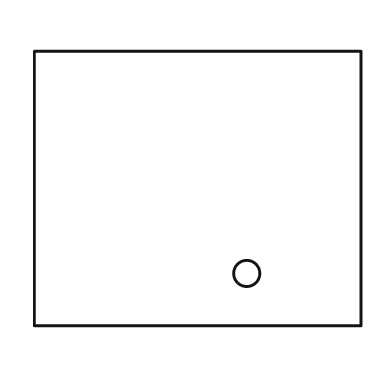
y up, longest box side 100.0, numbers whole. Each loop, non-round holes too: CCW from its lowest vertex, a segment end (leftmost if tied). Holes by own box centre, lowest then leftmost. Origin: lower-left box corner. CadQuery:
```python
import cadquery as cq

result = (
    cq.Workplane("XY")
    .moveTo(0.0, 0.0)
    .lineTo(100.0, 0.0)
    .lineTo(100.0, 84.0)
    .lineTo(0.0, 84.0)
    .close()
    .moveTo(65.0, 16.0)
    .circle(4.0)
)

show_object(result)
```